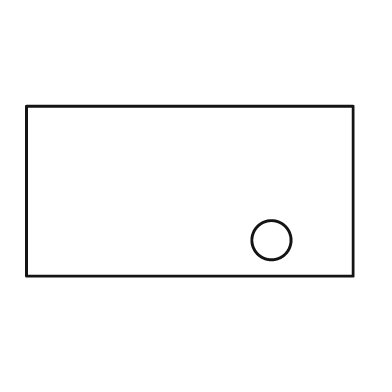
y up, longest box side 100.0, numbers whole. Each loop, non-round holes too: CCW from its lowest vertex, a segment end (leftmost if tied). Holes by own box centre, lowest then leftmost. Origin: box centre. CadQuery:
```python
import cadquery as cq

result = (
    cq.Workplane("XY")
    .moveTo(-50.0, -26.0)
    .lineTo(50.0, -26.0)
    .lineTo(50.0, 26.0)
    .lineTo(-50.0, 26.0)
    .close()
    .moveTo(25.0, -15.0)
    .circle(6.0)
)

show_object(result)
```